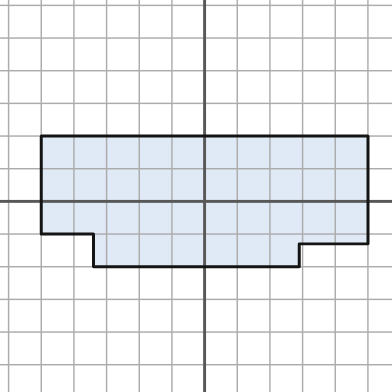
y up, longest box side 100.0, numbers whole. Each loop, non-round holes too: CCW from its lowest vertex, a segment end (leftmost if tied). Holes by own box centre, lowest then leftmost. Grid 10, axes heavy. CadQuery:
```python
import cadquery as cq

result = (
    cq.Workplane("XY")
    .moveTo(-34.0, -20.0)
    .lineTo(29.0, -20.0)
    .lineTo(29.0, -13.0)
    .lineTo(50.0, -13.0)
    .lineTo(50.0, 20.0)
    .lineTo(-50.0, 20.0)
    .lineTo(-50.0, -10.0)
    .lineTo(-34.0, -10.0)
    .close()
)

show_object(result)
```